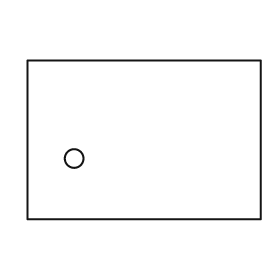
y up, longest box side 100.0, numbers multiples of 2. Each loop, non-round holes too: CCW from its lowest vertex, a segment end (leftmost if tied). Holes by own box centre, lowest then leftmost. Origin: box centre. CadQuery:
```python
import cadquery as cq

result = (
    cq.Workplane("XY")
    .moveTo(-50.0, -34.0)
    .lineTo(50.0, -34.0)
    .lineTo(50.0, 34.0)
    .lineTo(-50.0, 34.0)
    .close()
    .moveTo(-30.0, -8.0)
    .circle(4.0)
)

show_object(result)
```